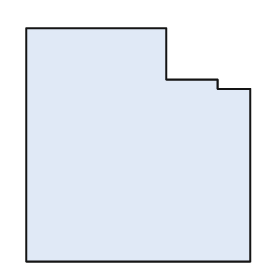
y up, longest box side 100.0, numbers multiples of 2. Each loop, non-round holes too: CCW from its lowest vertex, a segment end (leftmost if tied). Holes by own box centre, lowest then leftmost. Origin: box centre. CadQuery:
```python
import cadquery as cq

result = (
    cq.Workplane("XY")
    .moveTo(-48.0, -50.0)
    .lineTo(48.0, -50.0)
    .lineTo(48.0, 24.0)
    .lineTo(34.0, 24.0)
    .lineTo(34.0, 28.0)
    .lineTo(12.0, 28.0)
    .lineTo(12.0, 50.0)
    .lineTo(-48.0, 50.0)
    .close()
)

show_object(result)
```